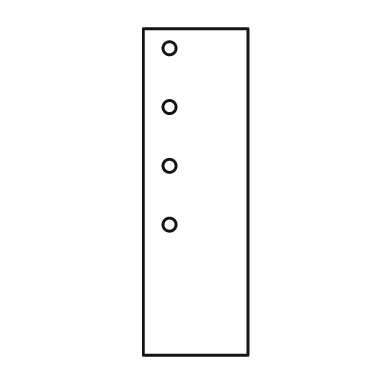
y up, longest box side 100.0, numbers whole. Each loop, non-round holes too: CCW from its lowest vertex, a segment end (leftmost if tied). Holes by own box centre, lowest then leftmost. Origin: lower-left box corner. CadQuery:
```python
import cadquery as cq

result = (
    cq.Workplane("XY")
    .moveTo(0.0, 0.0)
    .lineTo(32.0, 0.0)
    .lineTo(32.0, 100.0)
    .lineTo(0.0, 100.0)
    .close()
    .moveTo(8.0, 40.0)
    .circle(2.0)
    .moveTo(8.0, 58.0)
    .circle(2.0)
    .moveTo(8.0, 76.0)
    .circle(2.0)
    .moveTo(8.0, 94.0)
    .circle(2.0)
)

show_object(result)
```